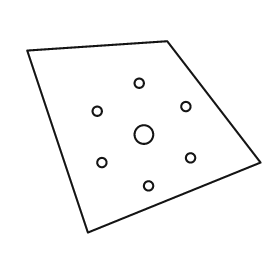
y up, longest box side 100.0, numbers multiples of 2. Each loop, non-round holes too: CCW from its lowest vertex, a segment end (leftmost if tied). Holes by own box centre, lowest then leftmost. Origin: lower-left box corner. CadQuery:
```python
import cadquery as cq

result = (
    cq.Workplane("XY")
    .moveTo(26.0, 0.0)
    .lineTo(100.0, 30.0)
    .lineTo(60.0, 82.0)
    .lineTo(0.0, 78.0)
    .close()
    .moveTo(52.0, 20.0)
    .circle(2.0)
    .moveTo(32.0, 30.0)
    .circle(2.0)
    .moveTo(70.0, 32.0)
    .circle(2.0)
    .moveTo(50.0, 42.0)
    .circle(4.0)
    .moveTo(30.0, 52.0)
    .circle(2.0)
    .moveTo(68.0, 54.0)
    .circle(2.0)
    .moveTo(48.0, 64.0)
    .circle(2.0)
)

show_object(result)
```